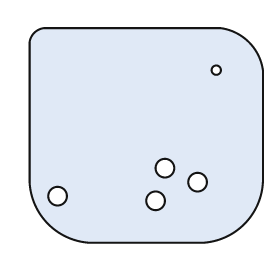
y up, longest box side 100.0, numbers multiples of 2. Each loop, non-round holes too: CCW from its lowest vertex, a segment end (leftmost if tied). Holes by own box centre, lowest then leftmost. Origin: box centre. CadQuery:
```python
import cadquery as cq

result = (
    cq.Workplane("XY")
    .moveTo(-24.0, -46.0)
    .lineTo(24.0, -46.0)
    .threePointArc((42.0, -38.0), (50.0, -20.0))
    .lineTo(50.0, 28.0)
    .threePointArc((44.0, 40.0), (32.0, 46.0))
    .lineTo(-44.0, 46.0)
    .threePointArc((-48.0, 44.0), (-50.0, 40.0))
    .lineTo(-50.0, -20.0)
    .threePointArc((-42.0, -38.0), (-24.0, -46.0))
    .close()
    .moveTo(4.0, -28.0)
    .circle(4.0)
    .moveTo(-38.0, -26.0)
    .circle(4.0)
    .moveTo(22.0, -20.0)
    .circle(4.0)
    .moveTo(8.0, -14.0)
    .circle(4.0)
    .moveTo(30.0, 28.0)
    .circle(2.0)
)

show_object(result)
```